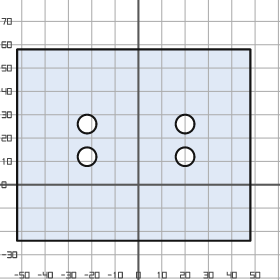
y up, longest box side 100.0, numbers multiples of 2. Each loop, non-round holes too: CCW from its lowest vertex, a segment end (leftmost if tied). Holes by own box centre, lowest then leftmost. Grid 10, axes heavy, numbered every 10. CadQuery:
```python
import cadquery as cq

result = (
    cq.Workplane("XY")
    .moveTo(-52.0, -24.0)
    .lineTo(48.0, -24.0)
    .lineTo(48.0, 58.0)
    .lineTo(-52.0, 58.0)
    .close()
    .moveTo(-22.0, 12.0)
    .circle(4.0)
    .moveTo(20.0, 12.0)
    .circle(4.0)
    .moveTo(-22.0, 26.0)
    .circle(4.0)
    .moveTo(20.0, 26.0)
    .circle(4.0)
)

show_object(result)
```